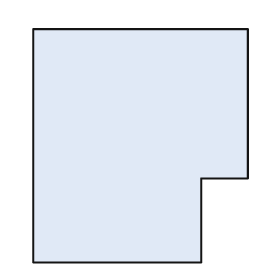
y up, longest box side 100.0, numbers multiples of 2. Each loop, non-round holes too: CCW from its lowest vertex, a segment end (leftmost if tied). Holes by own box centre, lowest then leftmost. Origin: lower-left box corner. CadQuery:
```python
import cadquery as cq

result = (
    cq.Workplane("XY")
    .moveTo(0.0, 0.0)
    .lineTo(72.0, 0.0)
    .lineTo(72.0, 36.0)
    .lineTo(92.0, 36.0)
    .lineTo(92.0, 100.0)
    .lineTo(0.0, 100.0)
    .close()
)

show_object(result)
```